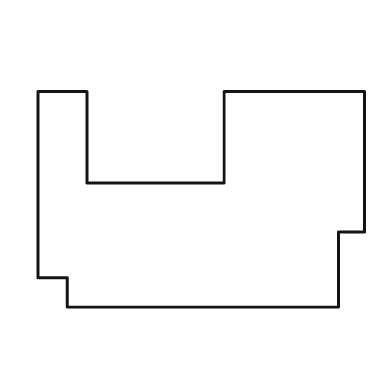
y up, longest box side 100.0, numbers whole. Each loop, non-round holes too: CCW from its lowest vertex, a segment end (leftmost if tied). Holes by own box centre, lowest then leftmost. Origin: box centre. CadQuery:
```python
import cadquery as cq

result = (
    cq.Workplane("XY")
    .moveTo(-41.0, -33.0)
    .lineTo(42.0, -33.0)
    .lineTo(42.0, -10.0)
    .lineTo(50.0, -10.0)
    .lineTo(50.0, 33.0)
    .lineTo(7.0, 33.0)
    .lineTo(7.0, 5.0)
    .lineTo(-35.0, 5.0)
    .lineTo(-35.0, 33.0)
    .lineTo(-50.0, 33.0)
    .lineTo(-50.0, -24.0)
    .lineTo(-41.0, -24.0)
    .close()
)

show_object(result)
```